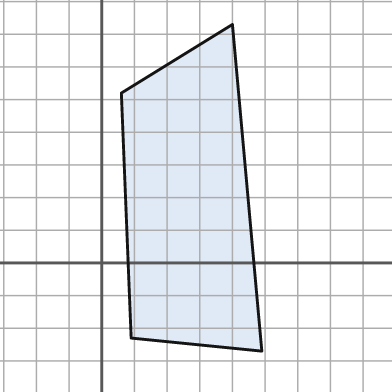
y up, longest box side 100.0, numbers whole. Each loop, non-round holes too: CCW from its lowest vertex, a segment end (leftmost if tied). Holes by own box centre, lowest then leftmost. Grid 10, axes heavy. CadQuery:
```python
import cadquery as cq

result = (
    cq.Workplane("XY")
    .moveTo(49.0, -27.0)
    .lineTo(40.0, 73.0)
    .lineTo(6.0, 52.0)
    .lineTo(9.0, -23.0)
    .close()
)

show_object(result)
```